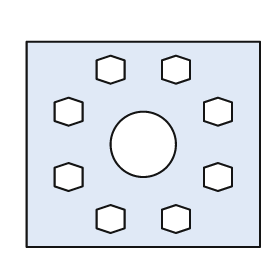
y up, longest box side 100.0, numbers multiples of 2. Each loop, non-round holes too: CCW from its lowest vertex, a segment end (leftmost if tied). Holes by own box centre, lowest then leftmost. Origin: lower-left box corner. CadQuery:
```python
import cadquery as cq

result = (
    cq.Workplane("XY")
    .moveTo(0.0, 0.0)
    .lineTo(100.0, 0.0)
    .lineTo(100.0, 88.0)
    .lineTo(0.0, 88.0)
    .close()
    .moveTo(36.0, 6.0)
    .lineTo(42.0, 8.0)
    .lineTo(42.0, 16.0)
    .lineTo(36.0, 18.0)
    .lineTo(30.0, 16.0)
    .lineTo(30.0, 8.0)
    .close()
    .moveTo(64.0, 6.0)
    .lineTo(70.0, 8.0)
    .lineTo(70.0, 16.0)
    .lineTo(64.0, 18.0)
    .lineTo(58.0, 16.0)
    .lineTo(58.0, 8.0)
    .close()
    .moveTo(18.0, 24.0)
    .lineTo(24.0, 26.0)
    .lineTo(24.0, 34.0)
    .lineTo(18.0, 36.0)
    .lineTo(12.0, 34.0)
    .lineTo(12.0, 26.0)
    .close()
    .moveTo(82.0, 24.0)
    .lineTo(88.0, 26.0)
    .lineTo(88.0, 34.0)
    .lineTo(82.0, 36.0)
    .lineTo(76.0, 34.0)
    .lineTo(76.0, 26.0)
    .close()
    .moveTo(50.0, 44.0)
    .circle(14.0)
    .moveTo(18.0, 52.0)
    .lineTo(24.0, 54.0)
    .lineTo(24.0, 62.0)
    .lineTo(18.0, 64.0)
    .lineTo(12.0, 62.0)
    .lineTo(12.0, 54.0)
    .close()
    .moveTo(82.0, 52.0)
    .lineTo(88.0, 54.0)
    .lineTo(88.0, 62.0)
    .lineTo(82.0, 64.0)
    .lineTo(76.0, 62.0)
    .lineTo(76.0, 54.0)
    .close()
    .moveTo(36.0, 70.0)
    .lineTo(42.0, 72.0)
    .lineTo(42.0, 80.0)
    .lineTo(36.0, 82.0)
    .lineTo(30.0, 80.0)
    .lineTo(30.0, 72.0)
    .close()
    .moveTo(64.0, 70.0)
    .lineTo(70.0, 72.0)
    .lineTo(70.0, 80.0)
    .lineTo(64.0, 82.0)
    .lineTo(58.0, 80.0)
    .lineTo(58.0, 72.0)
    .close()
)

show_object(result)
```